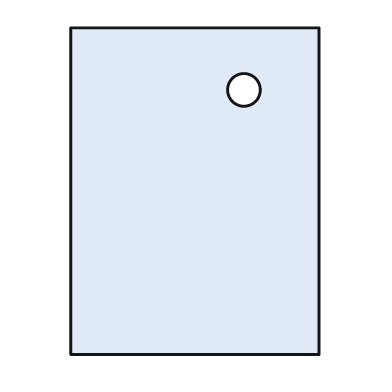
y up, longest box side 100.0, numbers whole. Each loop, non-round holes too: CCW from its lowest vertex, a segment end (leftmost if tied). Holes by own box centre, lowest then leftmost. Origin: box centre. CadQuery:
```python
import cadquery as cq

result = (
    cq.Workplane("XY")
    .moveTo(-38.0, -50.0)
    .lineTo(38.0, -50.0)
    .lineTo(38.0, 50.0)
    .lineTo(-38.0, 50.0)
    .close()
    .moveTo(15.0, 31.0)
    .circle(5.0)
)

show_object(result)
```